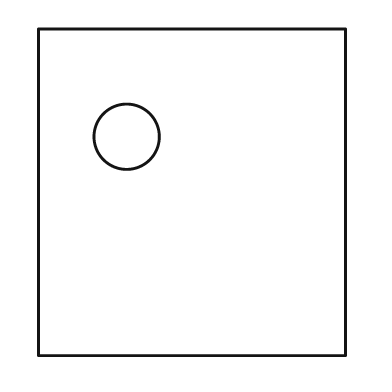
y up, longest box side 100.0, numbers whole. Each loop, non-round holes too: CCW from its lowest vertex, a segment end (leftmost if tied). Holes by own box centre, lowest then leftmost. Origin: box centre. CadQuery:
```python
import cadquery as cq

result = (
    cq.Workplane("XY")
    .moveTo(-47.0, -50.0)
    .lineTo(47.0, -50.0)
    .lineTo(47.0, 50.0)
    .lineTo(-47.0, 50.0)
    .close()
    .moveTo(-20.0, 17.0)
    .circle(10.0)
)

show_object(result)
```